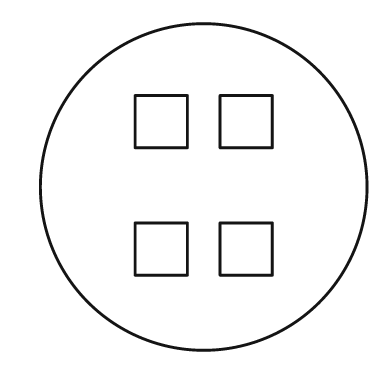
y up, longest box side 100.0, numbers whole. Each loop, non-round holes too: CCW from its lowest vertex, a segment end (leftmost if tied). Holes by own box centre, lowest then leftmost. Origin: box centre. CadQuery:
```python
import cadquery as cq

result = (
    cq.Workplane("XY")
    .moveTo(0.0, 0.0)
    .circle(50.0)
    .moveTo(-21.0, -27.0)
    .lineTo(-5.0, -27.0)
    .lineTo(-5.0, -11.0)
    .lineTo(-21.0, -11.0)
    .close()
    .moveTo(5.0, -27.0)
    .lineTo(21.0, -27.0)
    .lineTo(21.0, -11.0)
    .lineTo(5.0, -11.0)
    .close()
    .moveTo(-21.0, 12.0)
    .lineTo(-5.0, 12.0)
    .lineTo(-5.0, 28.0)
    .lineTo(-21.0, 28.0)
    .close()
    .moveTo(5.0, 12.0)
    .lineTo(21.0, 12.0)
    .lineTo(21.0, 28.0)
    .lineTo(5.0, 28.0)
    .close()
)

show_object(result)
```